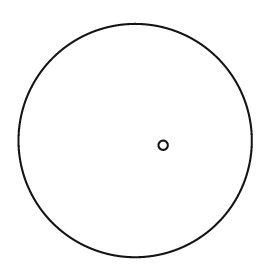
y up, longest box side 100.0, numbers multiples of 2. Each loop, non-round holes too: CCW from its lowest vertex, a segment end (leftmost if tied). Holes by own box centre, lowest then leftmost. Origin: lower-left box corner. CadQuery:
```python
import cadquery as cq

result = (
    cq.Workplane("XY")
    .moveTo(50.0, 50.0)
    .circle(50.0)
    .moveTo(62.0, 48.0)
    .circle(2.0)
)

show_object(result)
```